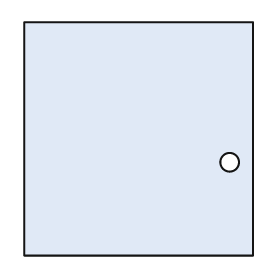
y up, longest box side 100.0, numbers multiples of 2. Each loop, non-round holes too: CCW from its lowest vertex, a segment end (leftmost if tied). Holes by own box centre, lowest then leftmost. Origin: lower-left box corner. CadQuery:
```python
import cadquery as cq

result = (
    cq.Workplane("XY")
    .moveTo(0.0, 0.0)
    .lineTo(98.0, 0.0)
    .lineTo(98.0, 100.0)
    .lineTo(0.0, 100.0)
    .close()
    .moveTo(88.0, 40.0)
    .circle(4.0)
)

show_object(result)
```